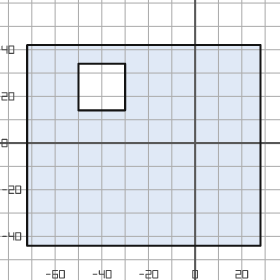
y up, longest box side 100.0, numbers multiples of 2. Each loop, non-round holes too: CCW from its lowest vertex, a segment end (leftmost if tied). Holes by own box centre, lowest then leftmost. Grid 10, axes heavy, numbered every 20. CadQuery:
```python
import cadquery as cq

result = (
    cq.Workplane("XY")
    .moveTo(-72.0, -44.0)
    .lineTo(28.0, -44.0)
    .lineTo(28.0, 42.0)
    .lineTo(-72.0, 42.0)
    .close()
    .moveTo(-50.0, 14.0)
    .lineTo(-30.0, 14.0)
    .lineTo(-30.0, 34.0)
    .lineTo(-50.0, 34.0)
    .close()
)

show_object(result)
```